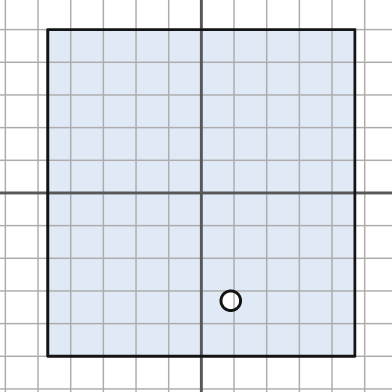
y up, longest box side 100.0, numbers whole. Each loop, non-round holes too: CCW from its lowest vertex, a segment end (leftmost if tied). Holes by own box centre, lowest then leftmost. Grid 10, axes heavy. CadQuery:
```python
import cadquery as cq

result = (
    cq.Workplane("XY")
    .moveTo(-47.0, -50.0)
    .lineTo(47.0, -50.0)
    .lineTo(47.0, 50.0)
    .lineTo(-47.0, 50.0)
    .close()
    .moveTo(9.0, -33.0)
    .circle(3.0)
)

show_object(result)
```